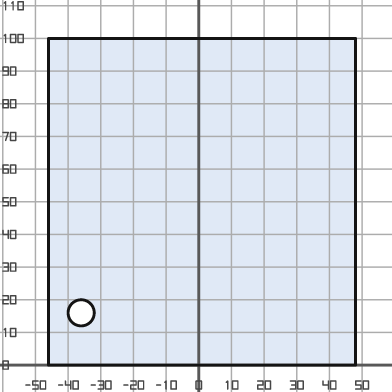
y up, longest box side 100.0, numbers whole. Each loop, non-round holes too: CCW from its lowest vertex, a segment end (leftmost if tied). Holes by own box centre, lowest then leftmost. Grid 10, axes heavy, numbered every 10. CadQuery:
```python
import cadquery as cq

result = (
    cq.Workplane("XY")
    .moveTo(-46.0, 0.0)
    .lineTo(48.0, 0.0)
    .lineTo(48.0, 100.0)
    .lineTo(-46.0, 100.0)
    .close()
    .moveTo(-36.0, 16.0)
    .circle(4.0)
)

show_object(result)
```